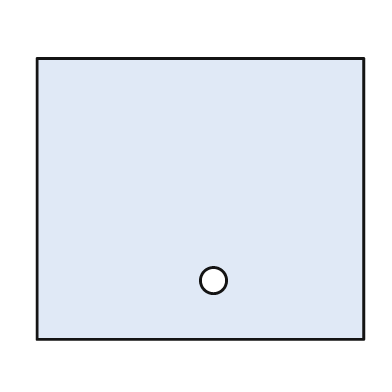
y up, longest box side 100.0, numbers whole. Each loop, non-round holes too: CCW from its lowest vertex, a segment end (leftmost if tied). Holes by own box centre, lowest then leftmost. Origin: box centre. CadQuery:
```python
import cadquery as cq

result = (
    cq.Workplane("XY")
    .moveTo(-50.0, -43.0)
    .lineTo(50.0, -43.0)
    .lineTo(50.0, 43.0)
    .lineTo(-50.0, 43.0)
    .close()
    .moveTo(4.0, -25.0)
    .circle(4.0)
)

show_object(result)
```